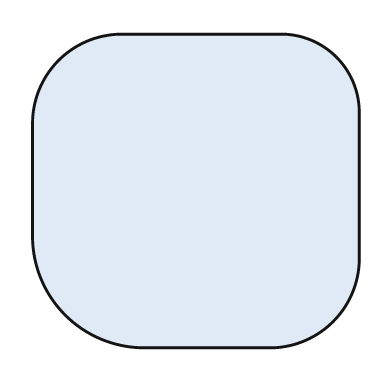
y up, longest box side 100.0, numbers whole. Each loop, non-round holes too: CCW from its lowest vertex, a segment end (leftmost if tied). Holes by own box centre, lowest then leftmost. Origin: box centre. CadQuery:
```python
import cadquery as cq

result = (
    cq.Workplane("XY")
    .moveTo(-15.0, -48.0)
    .lineTo(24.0, -48.0)
    .threePointArc((42.0, -40.0), (50.0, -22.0))
    .lineTo(50.0, 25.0)
    .threePointArc((43.0, 41.0), (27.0, 48.0))
    .lineTo(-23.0, 48.0)
    .threePointArc((-42.0, 40.0), (-50.0, 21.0))
    .lineTo(-50.0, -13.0)
    .threePointArc((-40.0, -38.0), (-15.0, -48.0))
    .close()
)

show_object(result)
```